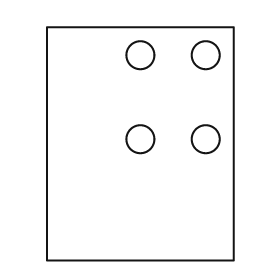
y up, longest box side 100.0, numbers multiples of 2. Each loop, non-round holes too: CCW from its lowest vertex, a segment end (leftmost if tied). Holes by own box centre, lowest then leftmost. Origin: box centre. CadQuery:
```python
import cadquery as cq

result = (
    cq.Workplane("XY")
    .moveTo(-40.0, -50.0)
    .lineTo(40.0, -50.0)
    .lineTo(40.0, 50.0)
    .lineTo(-40.0, 50.0)
    .close()
    .moveTo(0.0, 2.0)
    .circle(6.0)
    .moveTo(28.0, 2.0)
    .circle(6.0)
    .moveTo(0.0, 38.0)
    .circle(6.0)
    .moveTo(28.0, 38.0)
    .circle(6.0)
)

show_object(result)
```